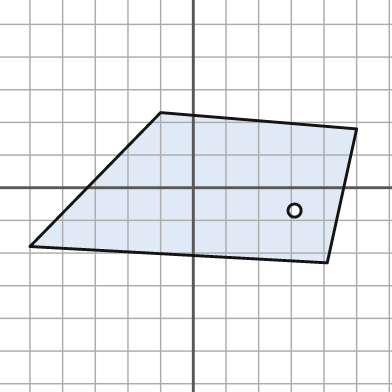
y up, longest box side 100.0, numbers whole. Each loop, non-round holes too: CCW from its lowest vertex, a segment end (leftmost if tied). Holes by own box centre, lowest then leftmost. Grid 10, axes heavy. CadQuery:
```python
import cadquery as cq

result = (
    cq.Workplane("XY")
    .moveTo(41.0, -23.0)
    .lineTo(50.0, 18.0)
    .lineTo(-10.0, 23.0)
    .lineTo(-50.0, -18.0)
    .close()
    .moveTo(31.0, -7.0)
    .circle(2.0)
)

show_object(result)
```